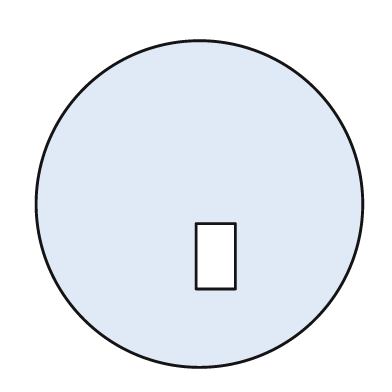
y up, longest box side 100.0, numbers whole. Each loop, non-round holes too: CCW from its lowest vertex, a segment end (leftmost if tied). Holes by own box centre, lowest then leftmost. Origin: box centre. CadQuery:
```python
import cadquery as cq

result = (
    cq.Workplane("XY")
    .moveTo(0.0, 0.0)
    .circle(50.0)
    .moveTo(-1.0, -26.0)
    .lineTo(11.0, -26.0)
    .lineTo(11.0, -6.0)
    .lineTo(-1.0, -6.0)
    .close()
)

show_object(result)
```